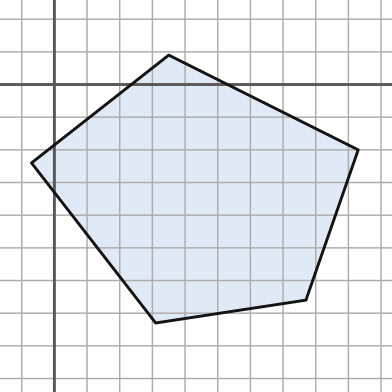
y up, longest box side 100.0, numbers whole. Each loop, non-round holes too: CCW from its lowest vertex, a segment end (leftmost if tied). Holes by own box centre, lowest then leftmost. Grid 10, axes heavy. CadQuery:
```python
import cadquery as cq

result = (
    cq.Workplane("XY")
    .moveTo(31.0, -73.0)
    .lineTo(77.0, -66.0)
    .lineTo(93.0, -20.0)
    .lineTo(35.0, 9.0)
    .lineTo(-7.0, -24.0)
    .close()
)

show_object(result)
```